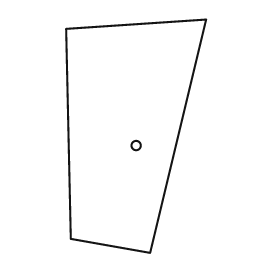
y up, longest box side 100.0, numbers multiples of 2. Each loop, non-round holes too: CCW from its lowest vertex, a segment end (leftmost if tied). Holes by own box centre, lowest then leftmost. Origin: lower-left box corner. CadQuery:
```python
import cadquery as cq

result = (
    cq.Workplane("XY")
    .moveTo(36.0, 0.0)
    .lineTo(60.0, 100.0)
    .lineTo(0.0, 96.0)
    .lineTo(2.0, 6.0)
    .close()
    .moveTo(30.0, 46.0)
    .circle(2.0)
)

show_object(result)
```